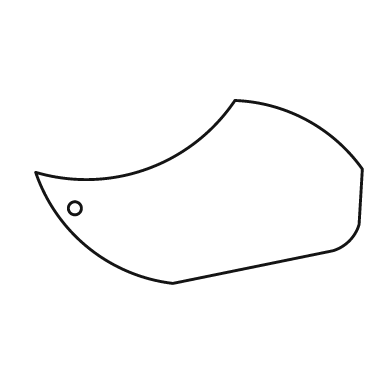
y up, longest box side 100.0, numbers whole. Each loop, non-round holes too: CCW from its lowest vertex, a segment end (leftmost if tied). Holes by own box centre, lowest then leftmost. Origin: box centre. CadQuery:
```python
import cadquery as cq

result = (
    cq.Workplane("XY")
    .moveTo(-8.0, -28.0)
    .lineTo(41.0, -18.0)
    .threePointArc((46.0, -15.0), (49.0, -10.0))
    .lineTo(50.0, 7.0)
    .threePointArc((33.0, 22.0), (11.0, 28.0))
    .threePointArc((-16.0, 7.0), (-50.0, 6.0))
    .threePointArc((-34.0, -17.0), (-8.0, -28.0))
    .close()
    .moveTo(-38.0, -5.0)
    .circle(2.0)
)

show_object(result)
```